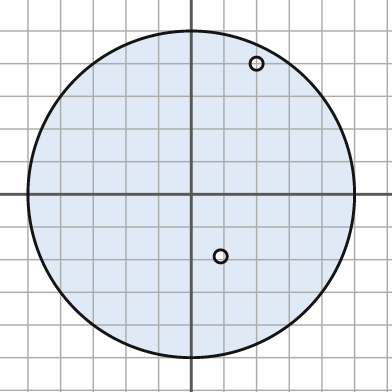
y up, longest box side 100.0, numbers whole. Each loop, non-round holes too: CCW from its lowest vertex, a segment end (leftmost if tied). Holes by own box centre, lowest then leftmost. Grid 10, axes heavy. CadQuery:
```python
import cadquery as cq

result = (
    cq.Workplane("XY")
    .moveTo(0.0, 0.0)
    .circle(50.0)
    .moveTo(9.0, -19.0)
    .circle(2.0)
    .moveTo(20.0, 40.0)
    .circle(2.0)
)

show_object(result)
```